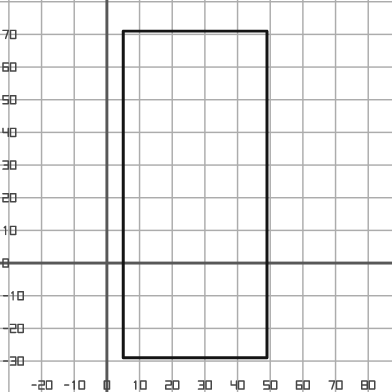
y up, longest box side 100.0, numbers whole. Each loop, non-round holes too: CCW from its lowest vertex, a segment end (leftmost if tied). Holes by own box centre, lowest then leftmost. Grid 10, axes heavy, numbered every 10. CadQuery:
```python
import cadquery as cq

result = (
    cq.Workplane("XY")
    .moveTo(5.0, -29.0)
    .lineTo(49.0, -29.0)
    .lineTo(49.0, 71.0)
    .lineTo(5.0, 71.0)
    .close()
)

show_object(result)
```